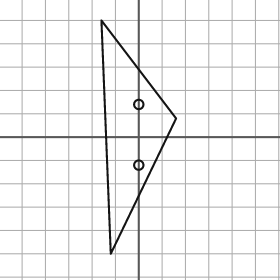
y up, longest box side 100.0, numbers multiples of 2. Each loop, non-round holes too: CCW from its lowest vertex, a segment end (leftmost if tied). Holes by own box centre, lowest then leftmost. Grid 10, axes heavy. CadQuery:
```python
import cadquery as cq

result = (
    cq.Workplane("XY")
    .moveTo(-12.0, -50.0)
    .lineTo(16.0, 8.0)
    .lineTo(-16.0, 50.0)
    .close()
    .moveTo(0.0, -12.0)
    .circle(2.0)
    .moveTo(0.0, 14.0)
    .circle(2.0)
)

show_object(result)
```